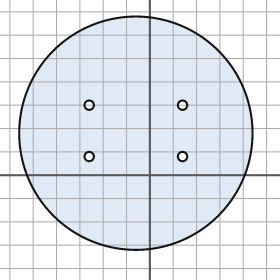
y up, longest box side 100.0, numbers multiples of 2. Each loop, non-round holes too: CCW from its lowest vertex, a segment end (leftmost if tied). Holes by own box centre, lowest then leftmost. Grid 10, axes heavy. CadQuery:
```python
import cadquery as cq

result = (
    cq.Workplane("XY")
    .moveTo(-6.0, 18.0)
    .circle(50.0)
    .moveTo(-26.0, 8.0)
    .circle(2.0)
    .moveTo(14.0, 8.0)
    .circle(2.0)
    .moveTo(-26.0, 30.0)
    .circle(2.0)
    .moveTo(14.0, 30.0)
    .circle(2.0)
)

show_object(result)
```